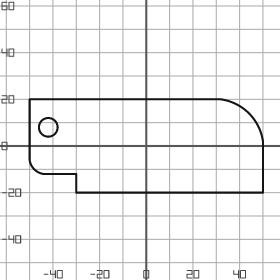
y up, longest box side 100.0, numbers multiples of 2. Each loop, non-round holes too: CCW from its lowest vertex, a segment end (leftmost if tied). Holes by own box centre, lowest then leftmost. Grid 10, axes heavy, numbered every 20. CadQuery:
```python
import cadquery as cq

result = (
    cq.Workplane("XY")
    .moveTo(-30.0, -20.0)
    .lineTo(50.0, -20.0)
    .lineTo(50.0, 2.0)
    .threePointArc((44.0, 14.0), (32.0, 20.0))
    .lineTo(-50.0, 20.0)
    .lineTo(-50.0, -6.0)
    .threePointArc((-48.0, -10.0), (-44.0, -12.0))
    .lineTo(-30.0, -12.0)
    .close()
    .moveTo(-42.0, 8.0)
    .circle(4.0)
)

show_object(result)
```